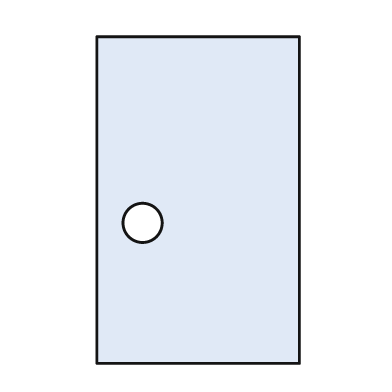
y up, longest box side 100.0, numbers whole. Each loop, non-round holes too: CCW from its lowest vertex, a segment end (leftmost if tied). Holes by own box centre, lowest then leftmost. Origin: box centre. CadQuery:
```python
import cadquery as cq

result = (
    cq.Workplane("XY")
    .moveTo(-31.0, -50.0)
    .lineTo(31.0, -50.0)
    .lineTo(31.0, 50.0)
    .lineTo(-31.0, 50.0)
    .close()
    .moveTo(-17.0, -7.0)
    .circle(6.0)
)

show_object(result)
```